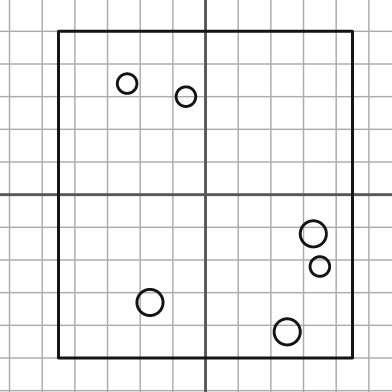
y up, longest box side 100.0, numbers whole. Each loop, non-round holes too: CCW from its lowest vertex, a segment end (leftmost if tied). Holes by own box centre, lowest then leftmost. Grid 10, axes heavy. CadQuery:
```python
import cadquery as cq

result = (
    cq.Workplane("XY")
    .moveTo(-45.0, -50.0)
    .lineTo(45.0, -50.0)
    .lineTo(45.0, 50.0)
    .lineTo(-45.0, 50.0)
    .close()
    .moveTo(25.0, -42.0)
    .circle(4.0)
    .moveTo(-17.0, -33.0)
    .circle(4.0)
    .moveTo(35.0, -22.0)
    .circle(3.0)
    .moveTo(33.0, -12.0)
    .circle(4.0)
    .moveTo(-6.0, 30.0)
    .circle(3.0)
    .moveTo(-24.0, 34.0)
    .circle(3.0)
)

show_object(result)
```